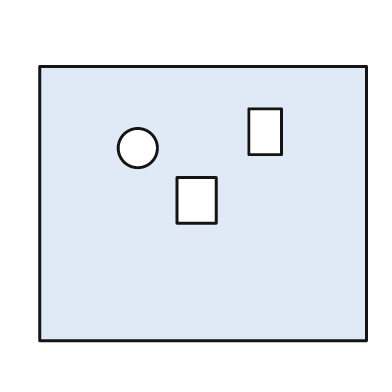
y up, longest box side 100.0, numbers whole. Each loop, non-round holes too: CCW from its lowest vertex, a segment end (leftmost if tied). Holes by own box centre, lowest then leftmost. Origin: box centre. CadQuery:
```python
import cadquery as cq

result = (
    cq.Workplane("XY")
    .moveTo(-50.0, -42.0)
    .lineTo(50.0, -42.0)
    .lineTo(50.0, 42.0)
    .lineTo(-50.0, 42.0)
    .close()
    .moveTo(-8.0, -6.0)
    .lineTo(4.0, -6.0)
    .lineTo(4.0, 8.0)
    .lineTo(-8.0, 8.0)
    .close()
    .moveTo(-20.0, 17.0)
    .circle(6.0)
    .moveTo(14.0, 15.0)
    .lineTo(24.0, 15.0)
    .lineTo(24.0, 29.0)
    .lineTo(14.0, 29.0)
    .close()
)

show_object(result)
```